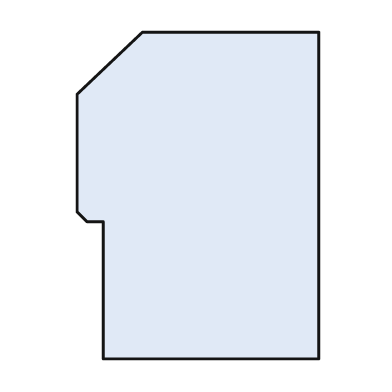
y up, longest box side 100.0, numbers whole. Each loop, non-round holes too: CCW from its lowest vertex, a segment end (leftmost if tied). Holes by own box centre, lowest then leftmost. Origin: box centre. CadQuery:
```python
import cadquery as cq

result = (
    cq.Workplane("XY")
    .moveTo(-29.0, -50.0)
    .lineTo(37.0, -50.0)
    .lineTo(37.0, 50.0)
    .lineTo(-17.0, 50.0)
    .lineTo(-37.0, 31.0)
    .lineTo(-37.0, -5.0)
    .lineTo(-34.0, -8.0)
    .lineTo(-29.0, -8.0)
    .close()
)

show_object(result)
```